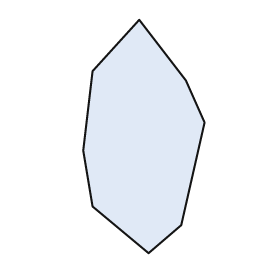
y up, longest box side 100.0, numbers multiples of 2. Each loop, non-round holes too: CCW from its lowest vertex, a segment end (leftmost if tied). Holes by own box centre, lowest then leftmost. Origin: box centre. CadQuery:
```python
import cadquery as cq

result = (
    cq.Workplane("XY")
    .moveTo(2.0, -50.0)
    .lineTo(16.0, -38.0)
    .lineTo(26.0, 6.0)
    .lineTo(18.0, 24.0)
    .lineTo(-2.0, 50.0)
    .lineTo(-22.0, 28.0)
    .lineTo(-26.0, -6.0)
    .lineTo(-22.0, -30.0)
    .close()
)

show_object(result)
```